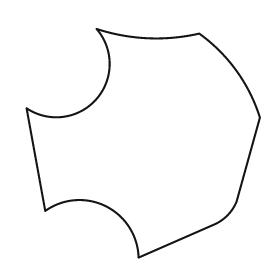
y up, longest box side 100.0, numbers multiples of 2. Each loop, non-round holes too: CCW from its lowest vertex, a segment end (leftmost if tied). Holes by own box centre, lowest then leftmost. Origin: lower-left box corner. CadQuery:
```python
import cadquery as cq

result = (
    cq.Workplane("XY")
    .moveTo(48.0, 0.0)
    .lineTo(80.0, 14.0)
    .threePointArc((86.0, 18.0), (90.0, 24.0))
    .lineTo(100.0, 60.0)
    .threePointArc((90.0, 80.0), (74.0, 96.0))
    .threePointArc((52.0, 94.0), (30.0, 98.0))
    .threePointArc((30.0, 68.0), (0.0, 64.0))
    .lineTo(8.0, 20.0)
    .threePointArc((34.0, 22.0), (48.0, 0.0))
    .close()
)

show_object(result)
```